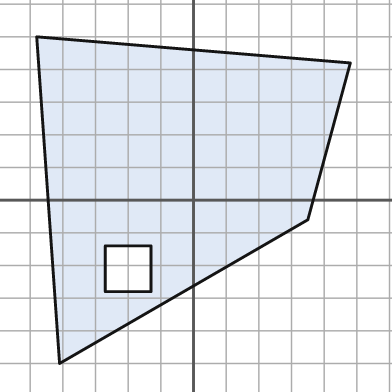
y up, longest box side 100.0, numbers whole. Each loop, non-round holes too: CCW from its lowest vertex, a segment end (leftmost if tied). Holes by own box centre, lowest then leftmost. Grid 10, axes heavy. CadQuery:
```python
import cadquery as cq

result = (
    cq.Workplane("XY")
    .moveTo(-41.0, -50.0)
    .lineTo(35.0, -6.0)
    .lineTo(48.0, 42.0)
    .lineTo(-48.0, 50.0)
    .close()
    .moveTo(-27.0, -28.0)
    .lineTo(-13.0, -28.0)
    .lineTo(-13.0, -14.0)
    .lineTo(-27.0, -14.0)
    .close()
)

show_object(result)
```